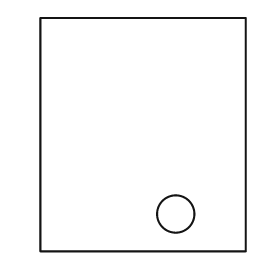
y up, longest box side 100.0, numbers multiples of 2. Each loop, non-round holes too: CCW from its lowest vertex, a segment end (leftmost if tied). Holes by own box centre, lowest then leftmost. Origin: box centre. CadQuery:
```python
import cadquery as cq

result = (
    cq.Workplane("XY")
    .moveTo(-44.0, -50.0)
    .lineTo(44.0, -50.0)
    .lineTo(44.0, 50.0)
    .lineTo(-44.0, 50.0)
    .close()
    .moveTo(14.0, -34.0)
    .circle(8.0)
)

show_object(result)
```